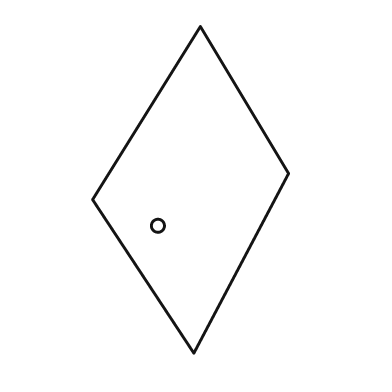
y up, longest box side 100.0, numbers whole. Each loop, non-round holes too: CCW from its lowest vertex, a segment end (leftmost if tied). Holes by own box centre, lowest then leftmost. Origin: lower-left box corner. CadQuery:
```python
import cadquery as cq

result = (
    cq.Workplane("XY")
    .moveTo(31.0, 0.0)
    .lineTo(60.0, 55.0)
    .lineTo(33.0, 100.0)
    .lineTo(0.0, 47.0)
    .close()
    .moveTo(20.0, 39.0)
    .circle(2.0)
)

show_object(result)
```